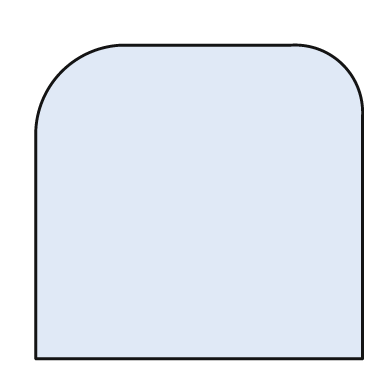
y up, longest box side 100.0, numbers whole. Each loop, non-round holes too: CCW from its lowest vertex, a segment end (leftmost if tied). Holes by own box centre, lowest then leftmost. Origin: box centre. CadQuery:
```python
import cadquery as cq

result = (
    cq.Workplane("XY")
    .moveTo(-50.0, -48.0)
    .lineTo(50.0, -48.0)
    .lineTo(50.0, 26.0)
    .threePointArc((44.0, 42.0), (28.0, 48.0))
    .lineTo(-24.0, 48.0)
    .threePointArc((-42.0, 40.0), (-50.0, 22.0))
    .close()
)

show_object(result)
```